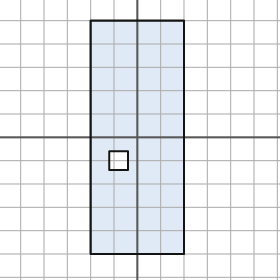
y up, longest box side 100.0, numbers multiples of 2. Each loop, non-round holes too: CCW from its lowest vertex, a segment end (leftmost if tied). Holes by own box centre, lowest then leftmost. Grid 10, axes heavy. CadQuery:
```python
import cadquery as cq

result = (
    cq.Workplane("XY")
    .moveTo(-20.0, -50.0)
    .lineTo(20.0, -50.0)
    .lineTo(20.0, 50.0)
    .lineTo(-20.0, 50.0)
    .close()
    .moveTo(-12.0, -14.0)
    .lineTo(-4.0, -14.0)
    .lineTo(-4.0, -6.0)
    .lineTo(-12.0, -6.0)
    .close()
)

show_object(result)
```